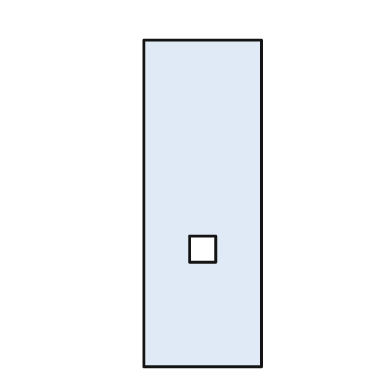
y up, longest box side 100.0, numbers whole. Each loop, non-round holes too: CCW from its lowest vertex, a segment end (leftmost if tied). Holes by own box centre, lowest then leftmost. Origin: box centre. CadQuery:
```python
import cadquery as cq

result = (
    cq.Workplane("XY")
    .moveTo(-18.0, -50.0)
    .lineTo(18.0, -50.0)
    .lineTo(18.0, 50.0)
    .lineTo(-18.0, 50.0)
    .close()
    .moveTo(-4.0, -18.0)
    .lineTo(4.0, -18.0)
    .lineTo(4.0, -10.0)
    .lineTo(-4.0, -10.0)
    .close()
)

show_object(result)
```